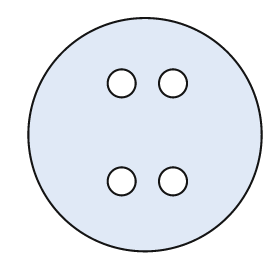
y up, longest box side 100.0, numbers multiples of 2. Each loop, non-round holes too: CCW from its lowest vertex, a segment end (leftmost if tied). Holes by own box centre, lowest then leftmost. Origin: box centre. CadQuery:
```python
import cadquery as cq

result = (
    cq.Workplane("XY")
    .moveTo(0.0, 0.0)
    .circle(50.0)
    .moveTo(-10.0, -20.0)
    .circle(6.0)
    .moveTo(12.0, -20.0)
    .circle(6.0)
    .moveTo(-10.0, 22.0)
    .circle(6.0)
    .moveTo(12.0, 22.0)
    .circle(6.0)
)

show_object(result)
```